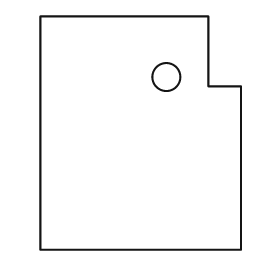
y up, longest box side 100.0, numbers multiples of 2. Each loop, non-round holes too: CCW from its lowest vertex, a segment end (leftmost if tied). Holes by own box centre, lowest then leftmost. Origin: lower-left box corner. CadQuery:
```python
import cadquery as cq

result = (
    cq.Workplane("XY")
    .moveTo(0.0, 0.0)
    .lineTo(86.0, 0.0)
    .lineTo(86.0, 70.0)
    .lineTo(72.0, 70.0)
    .lineTo(72.0, 100.0)
    .lineTo(0.0, 100.0)
    .close()
    .moveTo(54.0, 74.0)
    .circle(6.0)
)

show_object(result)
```